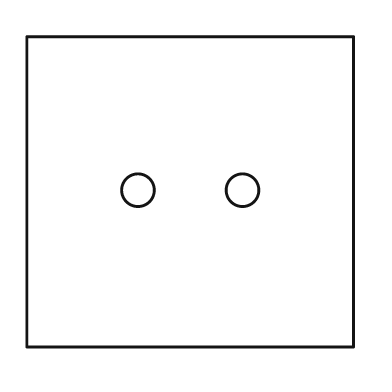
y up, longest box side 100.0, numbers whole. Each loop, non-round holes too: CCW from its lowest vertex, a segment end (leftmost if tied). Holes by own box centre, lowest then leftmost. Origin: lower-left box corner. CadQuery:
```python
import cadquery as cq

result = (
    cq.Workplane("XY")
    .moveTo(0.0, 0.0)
    .lineTo(100.0, 0.0)
    .lineTo(100.0, 95.0)
    .lineTo(0.0, 95.0)
    .close()
    .moveTo(34.0, 48.0)
    .circle(5.0)
    .moveTo(66.0, 48.0)
    .circle(5.0)
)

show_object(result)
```